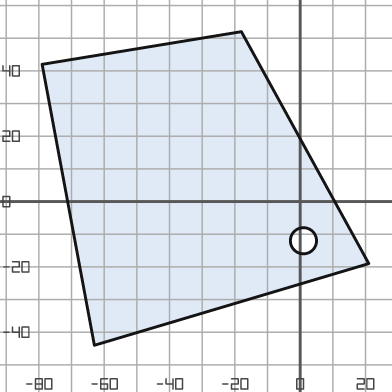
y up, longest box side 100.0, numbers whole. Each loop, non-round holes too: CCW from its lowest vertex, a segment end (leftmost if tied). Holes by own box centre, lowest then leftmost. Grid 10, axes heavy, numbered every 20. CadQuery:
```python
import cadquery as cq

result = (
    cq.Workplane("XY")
    .moveTo(-63.0, -44.0)
    .lineTo(21.0, -19.0)
    .lineTo(-18.0, 52.0)
    .lineTo(-79.0, 42.0)
    .close()
    .moveTo(1.0, -12.0)
    .circle(4.0)
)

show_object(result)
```